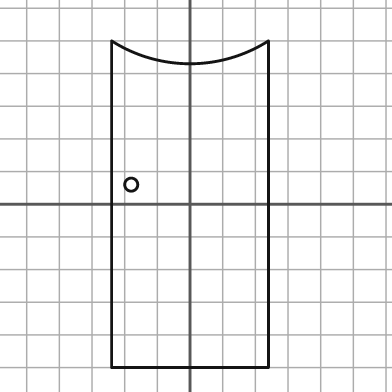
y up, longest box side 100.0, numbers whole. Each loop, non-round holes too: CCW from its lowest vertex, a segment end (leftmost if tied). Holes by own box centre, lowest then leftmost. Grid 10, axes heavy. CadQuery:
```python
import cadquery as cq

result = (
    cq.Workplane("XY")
    .moveTo(-24.0, -50.0)
    .lineTo(24.0, -50.0)
    .lineTo(24.0, 50.0)
    .threePointArc((0.0, 43.0), (-24.0, 50.0))
    .close()
    .moveTo(-18.0, 6.0)
    .circle(2.0)
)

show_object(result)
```